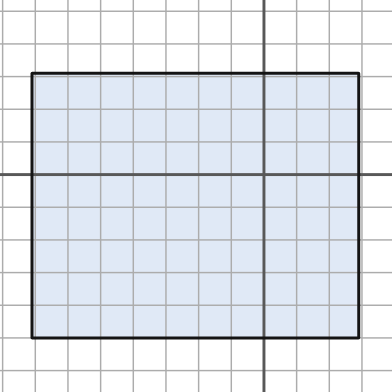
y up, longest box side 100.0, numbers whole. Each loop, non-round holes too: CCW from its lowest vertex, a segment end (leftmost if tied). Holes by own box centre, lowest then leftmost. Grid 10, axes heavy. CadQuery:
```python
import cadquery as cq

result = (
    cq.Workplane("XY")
    .moveTo(-71.0, -50.0)
    .lineTo(29.0, -50.0)
    .lineTo(29.0, 31.0)
    .lineTo(-71.0, 31.0)
    .close()
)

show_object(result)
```